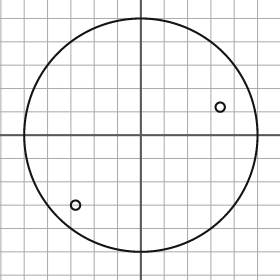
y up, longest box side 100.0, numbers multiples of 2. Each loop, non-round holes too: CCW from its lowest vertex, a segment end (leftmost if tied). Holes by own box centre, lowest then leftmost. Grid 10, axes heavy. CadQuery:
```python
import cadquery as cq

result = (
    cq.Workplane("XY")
    .moveTo(0.0, 0.0)
    .circle(50.0)
    .moveTo(-28.0, -30.0)
    .circle(2.0)
    .moveTo(34.0, 12.0)
    .circle(2.0)
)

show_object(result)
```